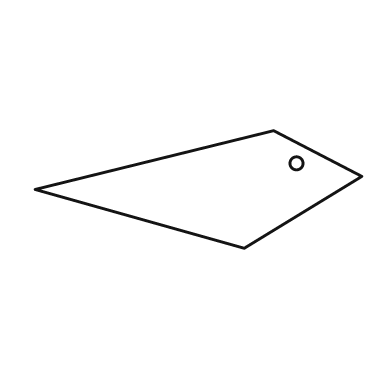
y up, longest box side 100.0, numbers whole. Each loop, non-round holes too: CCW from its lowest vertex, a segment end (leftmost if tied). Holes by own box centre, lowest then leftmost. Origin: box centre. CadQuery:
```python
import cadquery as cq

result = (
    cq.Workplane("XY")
    .moveTo(14.0, -18.0)
    .lineTo(50.0, 4.0)
    .lineTo(23.0, 18.0)
    .lineTo(-50.0, 0.0)
    .close()
    .moveTo(30.0, 8.0)
    .circle(2.0)
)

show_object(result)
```